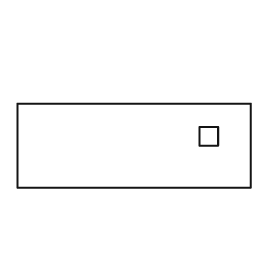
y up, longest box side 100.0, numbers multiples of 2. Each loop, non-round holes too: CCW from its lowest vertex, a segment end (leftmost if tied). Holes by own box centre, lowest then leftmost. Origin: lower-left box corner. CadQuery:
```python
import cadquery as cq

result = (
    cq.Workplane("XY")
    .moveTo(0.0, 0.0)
    .lineTo(100.0, 0.0)
    .lineTo(100.0, 36.0)
    .lineTo(0.0, 36.0)
    .close()
    .moveTo(78.0, 18.0)
    .lineTo(86.0, 18.0)
    .lineTo(86.0, 26.0)
    .lineTo(78.0, 26.0)
    .close()
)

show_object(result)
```